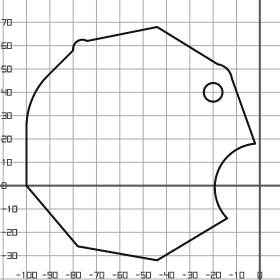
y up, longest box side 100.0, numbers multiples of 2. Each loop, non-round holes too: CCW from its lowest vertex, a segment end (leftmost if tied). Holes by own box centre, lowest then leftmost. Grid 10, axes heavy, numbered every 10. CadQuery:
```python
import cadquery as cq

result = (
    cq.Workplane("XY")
    .moveTo(-44.0, -32.0)
    .lineTo(-14.0, -14.0)
    .threePointArc((-18.0, 6.0), (-2.0, 18.0))
    .lineTo(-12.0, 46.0)
    .threePointArc((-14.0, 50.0), (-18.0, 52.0))
    .lineTo(-44.0, 68.0)
    .lineTo(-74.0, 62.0)
    .threePointArc((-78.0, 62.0), (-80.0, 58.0))
    .lineTo(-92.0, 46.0)
    .threePointArc((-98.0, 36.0), (-100.0, 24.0))
    .lineTo(-100.0, 0.0)
    .lineTo(-78.0, -26.0)
    .close()
    .moveTo(-20.0, 40.0)
    .circle(4.0)
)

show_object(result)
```